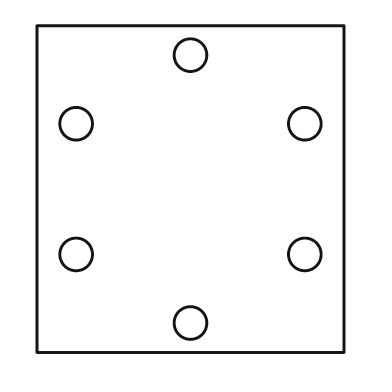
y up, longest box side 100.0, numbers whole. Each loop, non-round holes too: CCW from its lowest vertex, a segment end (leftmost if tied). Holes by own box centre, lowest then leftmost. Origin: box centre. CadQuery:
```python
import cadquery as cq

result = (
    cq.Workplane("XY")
    .moveTo(-47.0, -50.0)
    .lineTo(47.0, -50.0)
    .lineTo(47.0, 50.0)
    .lineTo(-47.0, 50.0)
    .close()
    .moveTo(0.0, -41.0)
    .circle(5.0)
    .moveTo(-35.0, -20.0)
    .circle(5.0)
    .moveTo(35.0, -20.0)
    .circle(5.0)
    .moveTo(-35.0, 20.0)
    .circle(5.0)
    .moveTo(35.0, 20.0)
    .circle(5.0)
    .moveTo(0.0, 41.0)
    .circle(5.0)
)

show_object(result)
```